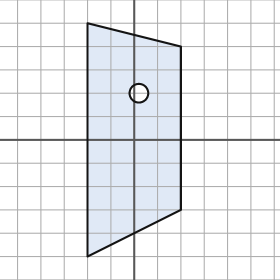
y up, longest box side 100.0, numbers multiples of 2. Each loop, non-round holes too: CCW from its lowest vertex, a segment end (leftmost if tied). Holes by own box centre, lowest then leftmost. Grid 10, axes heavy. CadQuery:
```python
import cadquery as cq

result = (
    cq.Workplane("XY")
    .moveTo(-20.0, -50.0)
    .lineTo(20.0, -30.0)
    .lineTo(20.0, 40.0)
    .lineTo(-20.0, 50.0)
    .close()
    .moveTo(2.0, 20.0)
    .circle(4.0)
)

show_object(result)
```